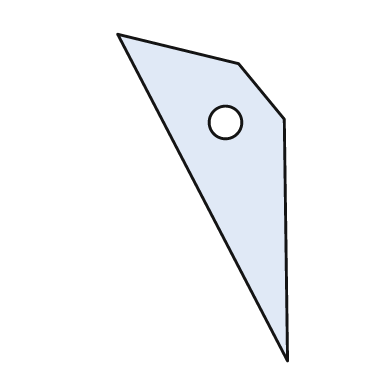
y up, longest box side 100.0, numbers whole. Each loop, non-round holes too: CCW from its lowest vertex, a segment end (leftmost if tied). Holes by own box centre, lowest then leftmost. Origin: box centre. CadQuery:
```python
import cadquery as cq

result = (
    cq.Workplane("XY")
    .moveTo(26.0, -50.0)
    .lineTo(25.0, 24.0)
    .lineTo(11.0, 41.0)
    .lineTo(-26.0, 50.0)
    .close()
    .moveTo(7.0, 23.0)
    .circle(5.0)
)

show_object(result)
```